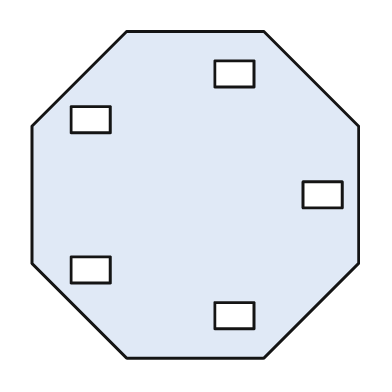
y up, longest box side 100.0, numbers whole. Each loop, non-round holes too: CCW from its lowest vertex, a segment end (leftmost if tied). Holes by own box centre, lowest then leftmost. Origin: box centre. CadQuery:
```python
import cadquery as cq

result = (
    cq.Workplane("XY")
    .moveTo(-21.0, -50.0)
    .lineTo(21.0, -50.0)
    .lineTo(50.0, -21.0)
    .lineTo(50.0, 21.0)
    .lineTo(21.0, 50.0)
    .lineTo(-21.0, 50.0)
    .lineTo(-50.0, 21.0)
    .lineTo(-50.0, -21.0)
    .close()
    .moveTo(6.0, -41.0)
    .lineTo(18.0, -41.0)
    .lineTo(18.0, -33.0)
    .lineTo(6.0, -33.0)
    .close()
    .moveTo(-38.0, -27.0)
    .lineTo(-26.0, -27.0)
    .lineTo(-26.0, -19.0)
    .lineTo(-38.0, -19.0)
    .close()
    .moveTo(33.0, -4.0)
    .lineTo(45.0, -4.0)
    .lineTo(45.0, 4.0)
    .lineTo(33.0, 4.0)
    .close()
    .moveTo(-38.0, 19.0)
    .lineTo(-26.0, 19.0)
    .lineTo(-26.0, 27.0)
    .lineTo(-38.0, 27.0)
    .close()
    .moveTo(6.0, 33.0)
    .lineTo(18.0, 33.0)
    .lineTo(18.0, 41.0)
    .lineTo(6.0, 41.0)
    .close()
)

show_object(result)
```